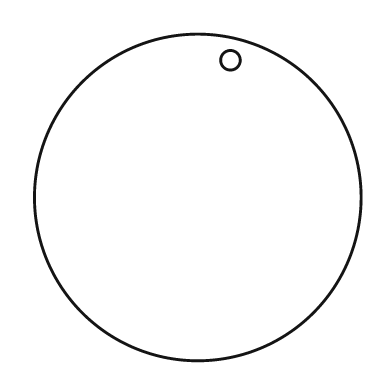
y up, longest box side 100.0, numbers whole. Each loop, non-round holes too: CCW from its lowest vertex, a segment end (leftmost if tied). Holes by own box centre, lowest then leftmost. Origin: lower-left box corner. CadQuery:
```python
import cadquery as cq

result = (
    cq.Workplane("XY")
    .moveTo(50.0, 50.0)
    .circle(50.0)
    .moveTo(60.0, 92.0)
    .circle(3.0)
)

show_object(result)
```